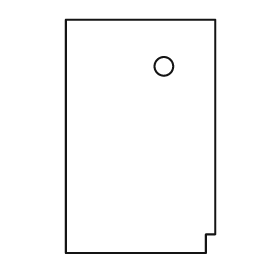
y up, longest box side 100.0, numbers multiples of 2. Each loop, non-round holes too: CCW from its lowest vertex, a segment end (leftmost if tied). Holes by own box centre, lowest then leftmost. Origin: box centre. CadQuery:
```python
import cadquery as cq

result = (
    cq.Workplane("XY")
    .moveTo(-32.0, -50.0)
    .lineTo(28.0, -50.0)
    .lineTo(28.0, -42.0)
    .lineTo(32.0, -42.0)
    .lineTo(32.0, 50.0)
    .lineTo(-32.0, 50.0)
    .close()
    .moveTo(10.0, 30.0)
    .circle(4.0)
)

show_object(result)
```